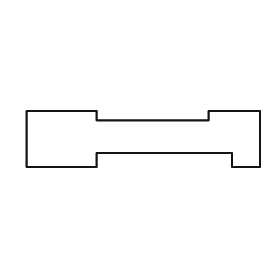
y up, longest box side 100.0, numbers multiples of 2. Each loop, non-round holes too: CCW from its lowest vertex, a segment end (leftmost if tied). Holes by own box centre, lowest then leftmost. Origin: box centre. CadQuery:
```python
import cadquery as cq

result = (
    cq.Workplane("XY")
    .moveTo(-50.0, -12.0)
    .lineTo(-20.0, -12.0)
    .lineTo(-20.0, -6.0)
    .lineTo(38.0, -6.0)
    .lineTo(38.0, -12.0)
    .lineTo(50.0, -12.0)
    .lineTo(50.0, 12.0)
    .lineTo(28.0, 12.0)
    .lineTo(28.0, 8.0)
    .lineTo(-20.0, 8.0)
    .lineTo(-20.0, 12.0)
    .lineTo(-50.0, 12.0)
    .close()
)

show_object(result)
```